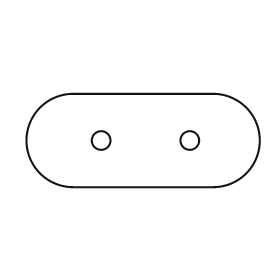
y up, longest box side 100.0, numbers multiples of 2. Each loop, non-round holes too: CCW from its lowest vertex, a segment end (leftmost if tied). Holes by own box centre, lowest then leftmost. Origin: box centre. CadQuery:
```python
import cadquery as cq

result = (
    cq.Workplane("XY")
    .moveTo(-30.0, -20.0)
    .lineTo(30.0, -20.0)
    .threePointArc((50.0, 0.0), (30.0, 20.0))
    .lineTo(-30.0, 20.0)
    .threePointArc((-50.0, 0.0), (-30.0, -20.0))
    .close()
    .moveTo(-18.0, 0.0)
    .circle(4.0)
    .moveTo(20.0, 0.0)
    .circle(4.0)
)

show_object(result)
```